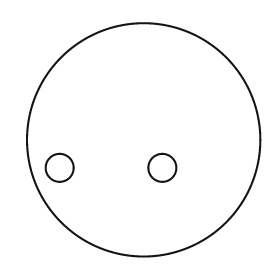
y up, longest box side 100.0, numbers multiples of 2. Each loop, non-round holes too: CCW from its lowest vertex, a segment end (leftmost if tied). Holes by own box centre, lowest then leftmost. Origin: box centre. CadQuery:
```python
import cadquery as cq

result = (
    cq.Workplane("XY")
    .moveTo(0.0, 0.0)
    .circle(50.0)
    .moveTo(-36.0, -12.0)
    .circle(6.0)
    .moveTo(8.0, -12.0)
    .circle(6.0)
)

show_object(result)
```